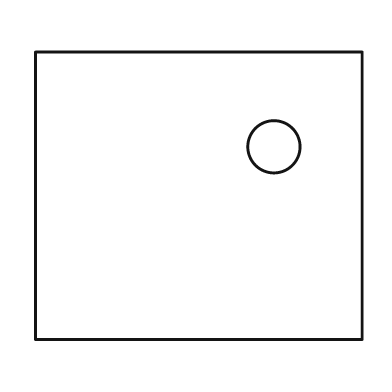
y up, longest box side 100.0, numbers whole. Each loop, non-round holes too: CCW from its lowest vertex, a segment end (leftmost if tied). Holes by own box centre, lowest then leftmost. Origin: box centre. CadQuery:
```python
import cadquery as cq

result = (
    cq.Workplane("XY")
    .moveTo(-50.0, -44.0)
    .lineTo(50.0, -44.0)
    .lineTo(50.0, 44.0)
    .lineTo(-50.0, 44.0)
    .close()
    .moveTo(23.0, 15.0)
    .circle(8.0)
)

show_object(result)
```